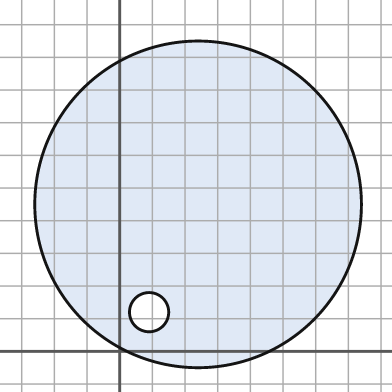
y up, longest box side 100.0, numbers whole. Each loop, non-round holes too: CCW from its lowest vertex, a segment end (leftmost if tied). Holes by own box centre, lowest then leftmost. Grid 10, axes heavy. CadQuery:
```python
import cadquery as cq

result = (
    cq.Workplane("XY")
    .moveTo(24.0, 45.0)
    .circle(50.0)
    .moveTo(9.0, 12.0)
    .circle(6.0)
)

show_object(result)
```